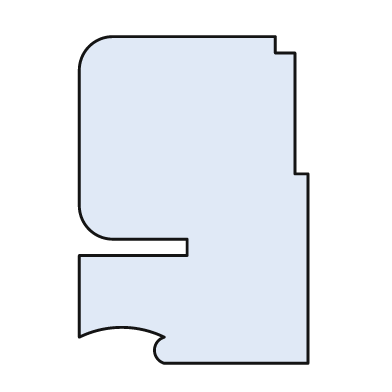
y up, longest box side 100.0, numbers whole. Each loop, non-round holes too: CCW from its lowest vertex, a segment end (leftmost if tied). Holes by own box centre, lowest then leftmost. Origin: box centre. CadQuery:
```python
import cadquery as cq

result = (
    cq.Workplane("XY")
    .moveTo(-9.0, -50.0)
    .lineTo(35.0, -50.0)
    .lineTo(35.0, 8.0)
    .lineTo(31.0, 8.0)
    .lineTo(31.0, 45.0)
    .lineTo(25.0, 45.0)
    .lineTo(25.0, 50.0)
    .lineTo(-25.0, 50.0)
    .threePointArc((-32.0, 47.0), (-35.0, 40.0))
    .lineTo(-35.0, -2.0)
    .threePointArc((-32.0, -9.0), (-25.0, -12.0))
    .lineTo(-2.0, -12.0)
    .lineTo(-2.0, -17.0)
    .lineTo(-35.0, -17.0)
    .lineTo(-35.0, -42.0)
    .threePointArc((-22.0, -39.0), (-9.0, -42.0))
    .threePointArc((-12.0, -46.0), (-9.0, -50.0))
    .close()
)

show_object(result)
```